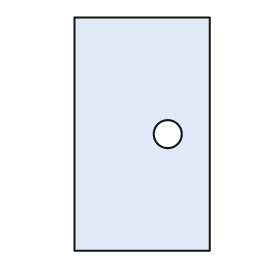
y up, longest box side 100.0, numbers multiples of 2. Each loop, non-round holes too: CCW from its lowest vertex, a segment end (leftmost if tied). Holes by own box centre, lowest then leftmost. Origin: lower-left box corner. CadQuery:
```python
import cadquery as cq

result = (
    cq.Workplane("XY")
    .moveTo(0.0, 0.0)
    .lineTo(58.0, 0.0)
    .lineTo(58.0, 100.0)
    .lineTo(0.0, 100.0)
    .close()
    .moveTo(40.0, 50.0)
    .circle(6.0)
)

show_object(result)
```